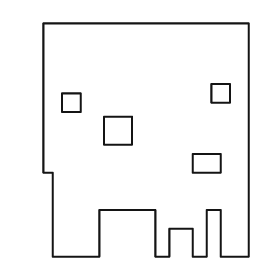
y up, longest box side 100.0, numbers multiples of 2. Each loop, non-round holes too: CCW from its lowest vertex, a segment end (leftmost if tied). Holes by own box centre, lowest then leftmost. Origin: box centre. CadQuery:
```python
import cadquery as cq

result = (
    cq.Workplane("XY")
    .moveTo(-40.0, -50.0)
    .lineTo(-20.0, -50.0)
    .lineTo(-20.0, -30.0)
    .lineTo(4.0, -30.0)
    .lineTo(4.0, -50.0)
    .lineTo(10.0, -50.0)
    .lineTo(10.0, -38.0)
    .lineTo(20.0, -38.0)
    .lineTo(20.0, -50.0)
    .lineTo(26.0, -50.0)
    .lineTo(26.0, -30.0)
    .lineTo(32.0, -30.0)
    .lineTo(32.0, -50.0)
    .lineTo(44.0, -50.0)
    .lineTo(44.0, 50.0)
    .lineTo(-44.0, 50.0)
    .lineTo(-44.0, -14.0)
    .lineTo(-40.0, -14.0)
    .close()
    .moveTo(20.0, -14.0)
    .lineTo(32.0, -14.0)
    .lineTo(32.0, -6.0)
    .lineTo(20.0, -6.0)
    .close()
    .moveTo(-18.0, -2.0)
    .lineTo(-6.0, -2.0)
    .lineTo(-6.0, 10.0)
    .lineTo(-18.0, 10.0)
    .close()
    .moveTo(-36.0, 12.0)
    .lineTo(-28.0, 12.0)
    .lineTo(-28.0, 20.0)
    .lineTo(-36.0, 20.0)
    .close()
    .moveTo(28.0, 16.0)
    .lineTo(36.0, 16.0)
    .lineTo(36.0, 24.0)
    .lineTo(28.0, 24.0)
    .close()
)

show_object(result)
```